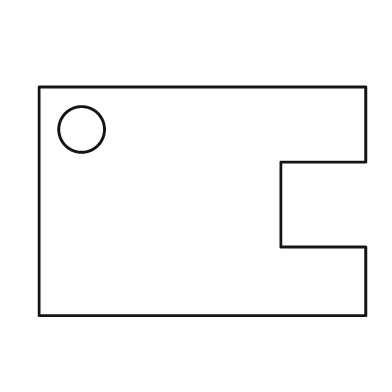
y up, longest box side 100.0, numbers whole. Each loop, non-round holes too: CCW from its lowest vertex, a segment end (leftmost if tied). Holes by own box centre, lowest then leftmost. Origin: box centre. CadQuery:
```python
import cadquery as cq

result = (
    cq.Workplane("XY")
    .moveTo(-50.0, -35.0)
    .lineTo(50.0, -35.0)
    .lineTo(50.0, -14.0)
    .lineTo(24.0, -14.0)
    .lineTo(24.0, 12.0)
    .lineTo(50.0, 12.0)
    .lineTo(50.0, 35.0)
    .lineTo(-50.0, 35.0)
    .close()
    .moveTo(-37.0, 22.0)
    .circle(7.0)
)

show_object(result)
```